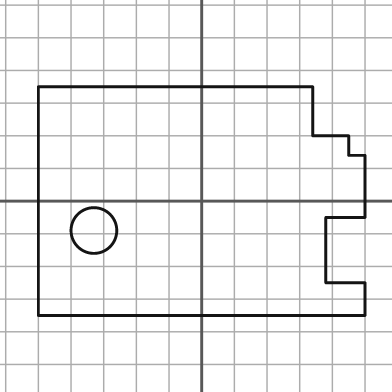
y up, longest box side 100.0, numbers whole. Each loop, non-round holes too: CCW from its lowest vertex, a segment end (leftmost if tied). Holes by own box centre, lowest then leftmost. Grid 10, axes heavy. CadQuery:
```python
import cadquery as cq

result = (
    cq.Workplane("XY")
    .moveTo(-50.0, -35.0)
    .lineTo(50.0, -35.0)
    .lineTo(50.0, -25.0)
    .lineTo(38.0, -25.0)
    .lineTo(38.0, -5.0)
    .lineTo(50.0, -5.0)
    .lineTo(50.0, 14.0)
    .lineTo(45.0, 14.0)
    .lineTo(45.0, 20.0)
    .lineTo(34.0, 20.0)
    .lineTo(34.0, 35.0)
    .lineTo(-50.0, 35.0)
    .close()
    .moveTo(-33.0, -9.0)
    .circle(7.0)
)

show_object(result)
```